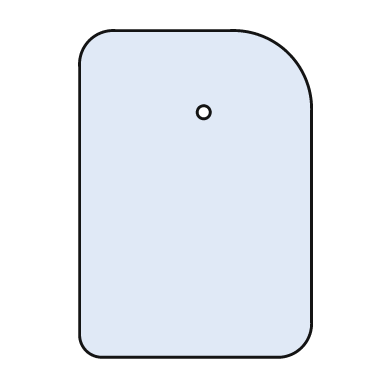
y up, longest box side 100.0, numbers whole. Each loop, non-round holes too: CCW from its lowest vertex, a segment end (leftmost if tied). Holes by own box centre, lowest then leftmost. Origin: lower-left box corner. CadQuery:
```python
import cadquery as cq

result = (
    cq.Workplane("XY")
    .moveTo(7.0, 0.0)
    .lineTo(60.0, 0.0)
    .threePointArc((68.0, 3.0), (71.0, 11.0))
    .lineTo(71.0, 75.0)
    .threePointArc((64.0, 93.0), (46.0, 100.0))
    .lineTo(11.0, 100.0)
    .threePointArc((3.0, 97.0), (0.0, 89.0))
    .lineTo(0.0, 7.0)
    .threePointArc((2.0, 2.0), (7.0, 0.0))
    .close()
    .moveTo(38.0, 75.0)
    .circle(2.0)
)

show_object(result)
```